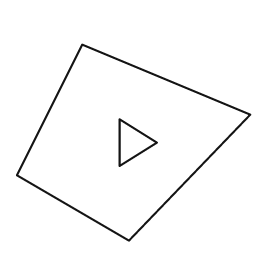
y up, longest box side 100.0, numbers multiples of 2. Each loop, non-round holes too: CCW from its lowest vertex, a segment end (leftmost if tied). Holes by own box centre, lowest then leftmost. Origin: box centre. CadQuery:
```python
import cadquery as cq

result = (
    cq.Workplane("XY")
    .moveTo(-2.0, -42.0)
    .lineTo(50.0, 12.0)
    .lineTo(-22.0, 42.0)
    .lineTo(-50.0, -14.0)
    .close()
    .moveTo(-6.0, -10.0)
    .lineTo(10.0, 0.0)
    .lineTo(-6.0, 10.0)
    .close()
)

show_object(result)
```